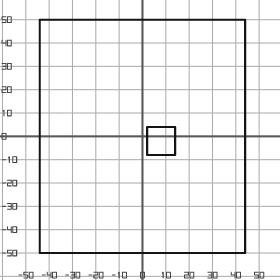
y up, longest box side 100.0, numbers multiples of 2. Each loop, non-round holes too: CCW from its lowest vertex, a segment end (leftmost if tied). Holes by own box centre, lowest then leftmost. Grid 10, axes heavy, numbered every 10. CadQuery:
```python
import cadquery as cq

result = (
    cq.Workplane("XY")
    .moveTo(-44.0, -50.0)
    .lineTo(44.0, -50.0)
    .lineTo(44.0, 50.0)
    .lineTo(-44.0, 50.0)
    .close()
    .moveTo(2.0, -8.0)
    .lineTo(14.0, -8.0)
    .lineTo(14.0, 4.0)
    .lineTo(2.0, 4.0)
    .close()
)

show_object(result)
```